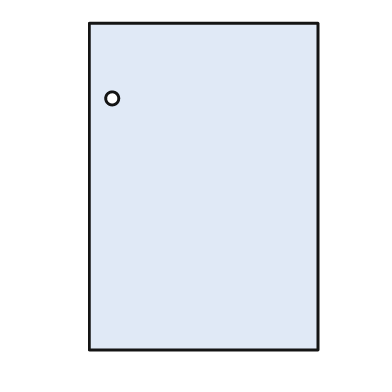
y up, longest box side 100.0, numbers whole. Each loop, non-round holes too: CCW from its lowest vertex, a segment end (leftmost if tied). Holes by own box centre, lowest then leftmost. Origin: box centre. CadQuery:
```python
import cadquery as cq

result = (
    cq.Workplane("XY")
    .moveTo(-35.0, -50.0)
    .lineTo(35.0, -50.0)
    .lineTo(35.0, 50.0)
    .lineTo(-35.0, 50.0)
    .close()
    .moveTo(-28.0, 27.0)
    .circle(2.0)
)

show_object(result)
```